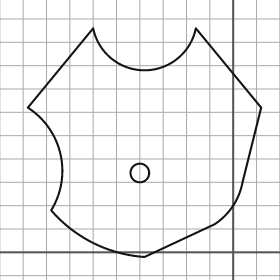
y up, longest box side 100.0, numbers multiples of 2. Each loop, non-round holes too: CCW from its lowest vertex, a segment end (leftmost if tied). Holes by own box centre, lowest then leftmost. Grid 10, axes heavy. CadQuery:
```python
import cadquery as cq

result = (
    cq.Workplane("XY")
    .moveTo(-38.0, -2.0)
    .lineTo(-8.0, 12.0)
    .threePointArc((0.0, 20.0), (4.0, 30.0))
    .lineTo(12.0, 62.0)
    .lineTo(-16.0, 96.0)
    .threePointArc((-38.0, 78.0), (-60.0, 96.0))
    .lineTo(-88.0, 62.0)
    .threePointArc((-74.0, 42.0), (-78.0, 18.0))
    .threePointArc((-60.0, 4.0), (-38.0, -2.0))
    .close()
    .moveTo(-40.0, 34.0)
    .circle(4.0)
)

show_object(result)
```